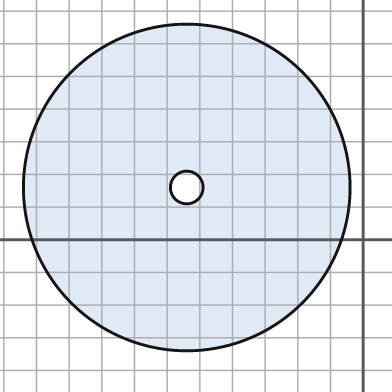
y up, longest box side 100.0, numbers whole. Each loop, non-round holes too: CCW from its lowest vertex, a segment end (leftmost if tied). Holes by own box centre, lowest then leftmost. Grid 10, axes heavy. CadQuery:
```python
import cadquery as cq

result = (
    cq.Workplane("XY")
    .moveTo(-54.0, 16.0)
    .circle(50.0)
    .moveTo(-54.0, 16.0)
    .circle(5.0)
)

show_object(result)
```